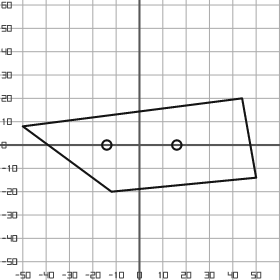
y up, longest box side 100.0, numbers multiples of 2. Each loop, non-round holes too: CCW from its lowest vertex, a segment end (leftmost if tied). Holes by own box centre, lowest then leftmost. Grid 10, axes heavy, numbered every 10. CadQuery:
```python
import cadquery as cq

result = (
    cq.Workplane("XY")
    .moveTo(-12.0, -20.0)
    .lineTo(50.0, -14.0)
    .lineTo(44.0, 20.0)
    .lineTo(-50.0, 8.0)
    .close()
    .moveTo(-14.0, 0.0)
    .circle(2.0)
    .moveTo(16.0, 0.0)
    .circle(2.0)
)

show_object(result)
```